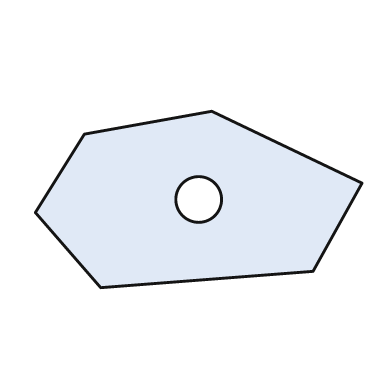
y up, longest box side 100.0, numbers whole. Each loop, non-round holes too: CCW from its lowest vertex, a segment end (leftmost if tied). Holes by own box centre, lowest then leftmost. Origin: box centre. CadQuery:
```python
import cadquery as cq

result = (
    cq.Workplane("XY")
    .moveTo(-30.0, -27.0)
    .lineTo(35.0, -22.0)
    .lineTo(50.0, 5.0)
    .lineTo(4.0, 27.0)
    .lineTo(-35.0, 20.0)
    .lineTo(-50.0, -4.0)
    .close()
    .moveTo(0.0, 0.0)
    .circle(7.0)
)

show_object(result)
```